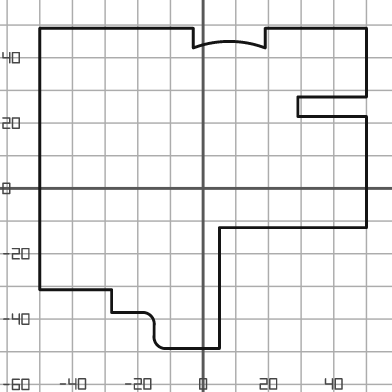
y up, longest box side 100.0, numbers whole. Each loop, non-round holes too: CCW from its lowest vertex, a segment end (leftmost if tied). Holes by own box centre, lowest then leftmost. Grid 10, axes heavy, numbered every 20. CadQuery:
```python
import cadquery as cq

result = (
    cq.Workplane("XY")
    .moveTo(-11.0, -49.0)
    .lineTo(5.0, -49.0)
    .lineTo(5.0, -12.0)
    .lineTo(50.0, -12.0)
    .lineTo(50.0, 22.0)
    .lineTo(29.0, 22.0)
    .lineTo(29.0, 28.0)
    .lineTo(50.0, 28.0)
    .lineTo(50.0, 49.0)
    .lineTo(19.0, 49.0)
    .lineTo(19.0, 43.0)
    .threePointArc((8.0, 45.0), (-3.0, 43.0))
    .lineTo(-3.0, 49.0)
    .lineTo(-50.0, 49.0)
    .lineTo(-50.0, -31.0)
    .lineTo(-28.0, -31.0)
    .lineTo(-28.0, -38.0)
    .lineTo(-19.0, -38.0)
    .threePointArc((-16.0, -39.0), (-15.0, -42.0))
    .lineTo(-15.0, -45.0)
    .threePointArc((-14.0, -48.0), (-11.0, -49.0))
    .close()
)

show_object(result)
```